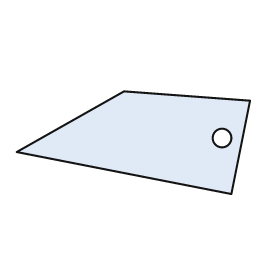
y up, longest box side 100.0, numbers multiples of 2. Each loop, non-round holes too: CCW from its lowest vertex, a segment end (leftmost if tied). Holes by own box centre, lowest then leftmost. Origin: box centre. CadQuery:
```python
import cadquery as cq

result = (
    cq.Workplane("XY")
    .moveTo(42.0, -22.0)
    .lineTo(50.0, 18.0)
    .lineTo(-4.0, 22.0)
    .lineTo(-50.0, -4.0)
    .close()
    .moveTo(38.0, 2.0)
    .circle(4.0)
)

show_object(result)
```